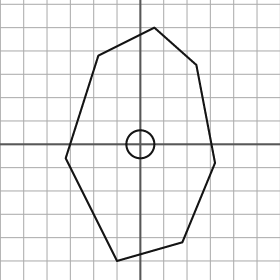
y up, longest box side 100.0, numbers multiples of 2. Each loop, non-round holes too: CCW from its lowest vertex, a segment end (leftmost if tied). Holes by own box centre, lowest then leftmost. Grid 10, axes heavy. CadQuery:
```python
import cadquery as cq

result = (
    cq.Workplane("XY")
    .moveTo(-10.0, -50.0)
    .lineTo(18.0, -42.0)
    .lineTo(32.0, -8.0)
    .lineTo(24.0, 34.0)
    .lineTo(6.0, 50.0)
    .lineTo(-18.0, 38.0)
    .lineTo(-32.0, -6.0)
    .close()
    .moveTo(0.0, 0.0)
    .circle(6.0)
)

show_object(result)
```